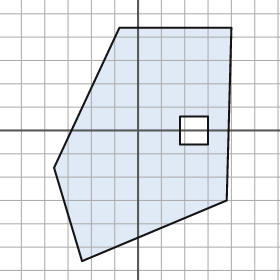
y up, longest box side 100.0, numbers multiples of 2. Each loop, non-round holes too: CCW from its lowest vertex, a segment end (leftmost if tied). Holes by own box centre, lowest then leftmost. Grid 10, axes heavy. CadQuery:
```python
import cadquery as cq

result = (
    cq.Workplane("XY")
    .moveTo(-24.0, -56.0)
    .lineTo(38.0, -30.0)
    .lineTo(40.0, 44.0)
    .lineTo(-8.0, 44.0)
    .lineTo(-36.0, -16.0)
    .close()
    .moveTo(18.0, -6.0)
    .lineTo(30.0, -6.0)
    .lineTo(30.0, 6.0)
    .lineTo(18.0, 6.0)
    .close()
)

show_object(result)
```